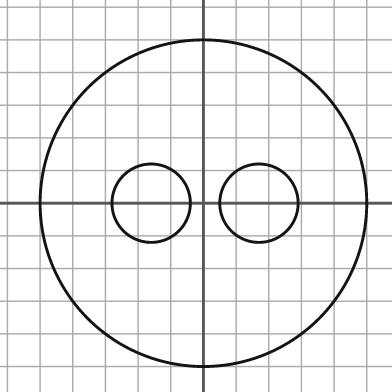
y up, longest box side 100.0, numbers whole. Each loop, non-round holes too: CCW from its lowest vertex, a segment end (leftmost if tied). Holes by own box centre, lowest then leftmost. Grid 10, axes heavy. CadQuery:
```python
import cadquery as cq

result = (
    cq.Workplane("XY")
    .moveTo(0.0, 0.0)
    .circle(50.0)
    .moveTo(-16.0, 0.0)
    .circle(12.0)
    .moveTo(17.0, 0.0)
    .circle(12.0)
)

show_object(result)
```